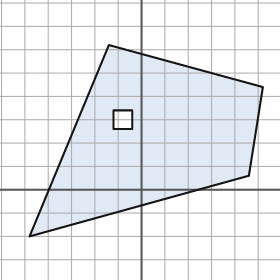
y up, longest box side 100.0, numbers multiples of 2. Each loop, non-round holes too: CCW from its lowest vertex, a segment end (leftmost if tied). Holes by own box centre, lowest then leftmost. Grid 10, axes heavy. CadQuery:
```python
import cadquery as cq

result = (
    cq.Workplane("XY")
    .moveTo(-48.0, -20.0)
    .lineTo(46.0, 6.0)
    .lineTo(52.0, 44.0)
    .lineTo(-14.0, 62.0)
    .close()
    .moveTo(-12.0, 26.0)
    .lineTo(-4.0, 26.0)
    .lineTo(-4.0, 34.0)
    .lineTo(-12.0, 34.0)
    .close()
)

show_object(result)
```